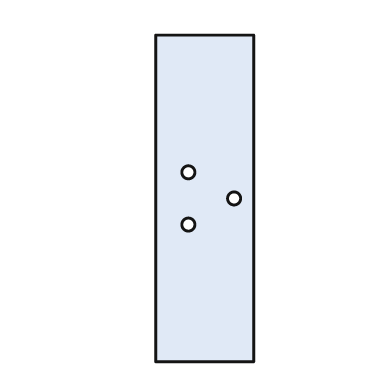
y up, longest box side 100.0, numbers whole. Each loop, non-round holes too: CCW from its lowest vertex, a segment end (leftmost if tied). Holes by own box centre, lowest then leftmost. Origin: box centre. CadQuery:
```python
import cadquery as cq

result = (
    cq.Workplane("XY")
    .moveTo(-15.0, -50.0)
    .lineTo(15.0, -50.0)
    .lineTo(15.0, 50.0)
    .lineTo(-15.0, 50.0)
    .close()
    .moveTo(-5.0, -8.0)
    .circle(2.0)
    .moveTo(9.0, 0.0)
    .circle(2.0)
    .moveTo(-5.0, 8.0)
    .circle(2.0)
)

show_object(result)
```